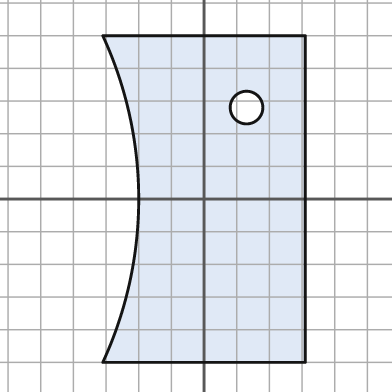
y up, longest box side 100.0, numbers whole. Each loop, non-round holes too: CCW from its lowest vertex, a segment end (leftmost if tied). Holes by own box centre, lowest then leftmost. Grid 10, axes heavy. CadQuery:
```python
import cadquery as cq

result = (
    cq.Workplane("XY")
    .moveTo(-31.0, -50.0)
    .lineTo(31.0, -50.0)
    .lineTo(31.0, 50.0)
    .lineTo(-31.0, 50.0)
    .threePointArc((-20.0, 0.0), (-31.0, -50.0))
    .close()
    .moveTo(13.0, 28.0)
    .circle(5.0)
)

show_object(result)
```